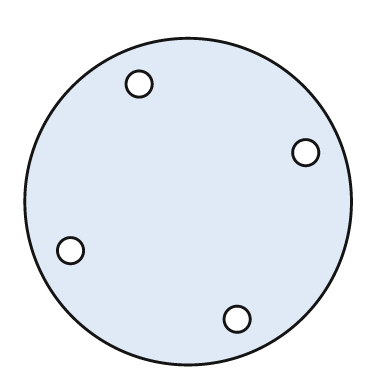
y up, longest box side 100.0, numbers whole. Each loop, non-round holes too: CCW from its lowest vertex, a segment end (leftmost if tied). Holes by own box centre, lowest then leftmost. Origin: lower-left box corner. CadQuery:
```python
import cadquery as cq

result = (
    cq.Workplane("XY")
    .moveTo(50.0, 50.0)
    .circle(50.0)
    .moveTo(65.0, 14.0)
    .circle(4.0)
    .moveTo(14.0, 35.0)
    .circle(4.0)
    .moveTo(86.0, 65.0)
    .circle(4.0)
    .moveTo(35.0, 86.0)
    .circle(4.0)
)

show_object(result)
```